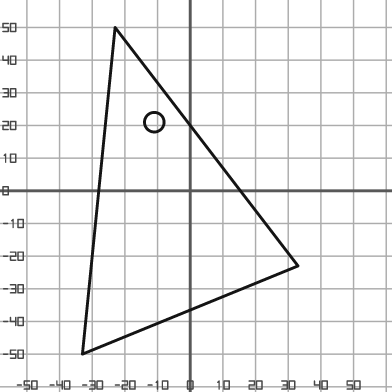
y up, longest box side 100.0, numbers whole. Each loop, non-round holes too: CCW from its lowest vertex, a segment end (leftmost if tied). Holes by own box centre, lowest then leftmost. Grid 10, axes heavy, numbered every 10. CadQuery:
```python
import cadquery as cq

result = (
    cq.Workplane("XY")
    .moveTo(-33.0, -50.0)
    .lineTo(33.0, -23.0)
    .lineTo(-23.0, 50.0)
    .close()
    .moveTo(-11.0, 21.0)
    .circle(3.0)
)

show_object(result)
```